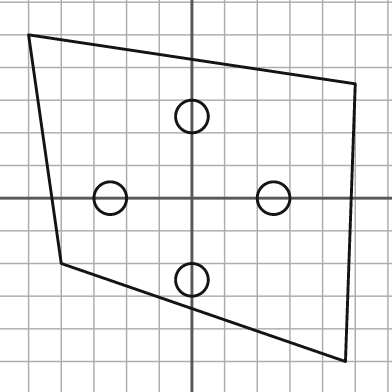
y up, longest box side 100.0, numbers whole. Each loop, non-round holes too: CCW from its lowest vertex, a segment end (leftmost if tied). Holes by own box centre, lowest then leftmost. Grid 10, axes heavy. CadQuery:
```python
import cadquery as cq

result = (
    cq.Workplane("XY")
    .moveTo(47.0, -50.0)
    .lineTo(50.0, 35.0)
    .lineTo(-50.0, 50.0)
    .lineTo(-40.0, -20.0)
    .close()
    .moveTo(0.0, -25.0)
    .circle(5.0)
    .moveTo(-25.0, 0.0)
    .circle(5.0)
    .moveTo(25.0, 0.0)
    .circle(5.0)
    .moveTo(0.0, 25.0)
    .circle(5.0)
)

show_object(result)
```